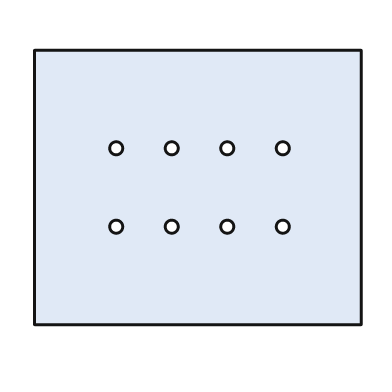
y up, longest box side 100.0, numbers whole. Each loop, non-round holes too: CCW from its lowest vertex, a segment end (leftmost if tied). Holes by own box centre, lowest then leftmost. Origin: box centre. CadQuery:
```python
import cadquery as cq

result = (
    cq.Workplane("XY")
    .moveTo(-50.0, -42.0)
    .lineTo(50.0, -42.0)
    .lineTo(50.0, 42.0)
    .lineTo(-50.0, 42.0)
    .close()
    .moveTo(-25.0, -12.0)
    .circle(2.0)
    .moveTo(-8.0, -12.0)
    .circle(2.0)
    .moveTo(9.0, -12.0)
    .circle(2.0)
    .moveTo(26.0, -12.0)
    .circle(2.0)
    .moveTo(-25.0, 12.0)
    .circle(2.0)
    .moveTo(-8.0, 12.0)
    .circle(2.0)
    .moveTo(9.0, 12.0)
    .circle(2.0)
    .moveTo(26.0, 12.0)
    .circle(2.0)
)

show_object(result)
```